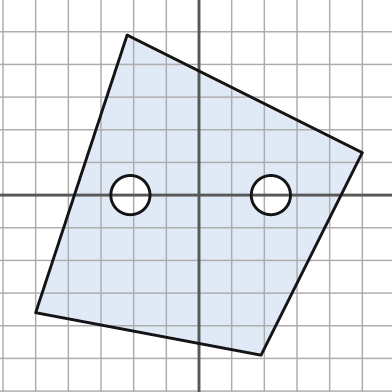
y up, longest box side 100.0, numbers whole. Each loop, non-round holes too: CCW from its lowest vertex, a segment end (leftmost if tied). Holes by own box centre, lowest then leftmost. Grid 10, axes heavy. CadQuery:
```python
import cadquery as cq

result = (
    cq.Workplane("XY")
    .moveTo(19.0, -49.0)
    .lineTo(50.0, 13.0)
    .lineTo(-22.0, 49.0)
    .lineTo(-50.0, -36.0)
    .close()
    .moveTo(-21.0, 0.0)
    .circle(6.0)
    .moveTo(22.0, 0.0)
    .circle(6.0)
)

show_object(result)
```